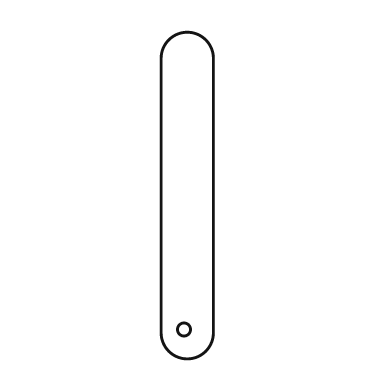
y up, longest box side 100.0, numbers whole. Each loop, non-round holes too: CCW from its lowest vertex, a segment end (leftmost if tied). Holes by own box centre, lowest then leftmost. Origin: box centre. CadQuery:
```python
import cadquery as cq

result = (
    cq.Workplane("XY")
    .moveTo(-8.0, -42.0)
    .threePointArc((0.0, -50.0), (8.0, -42.0))
    .lineTo(8.0, 42.0)
    .threePointArc((0.0, 50.0), (-8.0, 42.0))
    .close()
    .moveTo(-1.0, -41.0)
    .circle(2.0)
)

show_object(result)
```